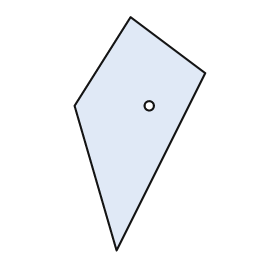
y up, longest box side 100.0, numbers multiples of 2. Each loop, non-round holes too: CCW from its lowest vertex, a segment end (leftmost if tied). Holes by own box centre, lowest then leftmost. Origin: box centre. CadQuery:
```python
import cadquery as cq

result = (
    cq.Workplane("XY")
    .moveTo(-10.0, -50.0)
    .lineTo(28.0, 26.0)
    .lineTo(-4.0, 50.0)
    .lineTo(-28.0, 12.0)
    .close()
    .moveTo(4.0, 12.0)
    .circle(2.0)
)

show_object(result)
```